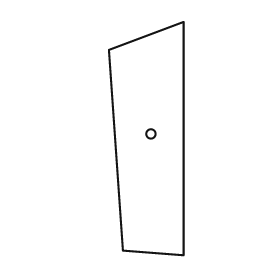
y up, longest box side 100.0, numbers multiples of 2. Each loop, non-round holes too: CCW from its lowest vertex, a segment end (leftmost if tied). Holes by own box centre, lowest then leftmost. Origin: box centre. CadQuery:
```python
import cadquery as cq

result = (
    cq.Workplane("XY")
    .moveTo(16.0, -50.0)
    .lineTo(16.0, 50.0)
    .lineTo(-16.0, 38.0)
    .lineTo(-10.0, -48.0)
    .close()
    .moveTo(2.0, 2.0)
    .circle(2.0)
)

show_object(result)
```